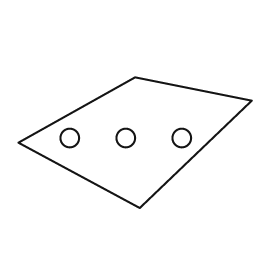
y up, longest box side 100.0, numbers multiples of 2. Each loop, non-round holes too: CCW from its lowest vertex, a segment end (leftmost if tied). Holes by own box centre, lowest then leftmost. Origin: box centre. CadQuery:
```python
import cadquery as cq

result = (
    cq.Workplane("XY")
    .moveTo(2.0, -28.0)
    .lineTo(50.0, 18.0)
    .lineTo(0.0, 28.0)
    .lineTo(-50.0, 0.0)
    .close()
    .moveTo(-28.0, 2.0)
    .circle(4.0)
    .moveTo(-4.0, 2.0)
    .circle(4.0)
    .moveTo(20.0, 2.0)
    .circle(4.0)
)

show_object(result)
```